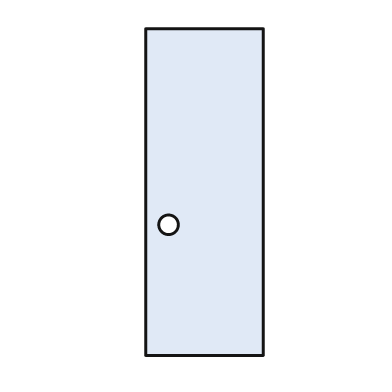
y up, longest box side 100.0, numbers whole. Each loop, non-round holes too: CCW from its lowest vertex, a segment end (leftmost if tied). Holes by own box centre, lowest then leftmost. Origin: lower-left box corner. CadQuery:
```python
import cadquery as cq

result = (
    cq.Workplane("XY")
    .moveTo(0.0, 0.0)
    .lineTo(36.0, 0.0)
    .lineTo(36.0, 100.0)
    .lineTo(0.0, 100.0)
    .close()
    .moveTo(7.0, 40.0)
    .circle(3.0)
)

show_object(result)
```